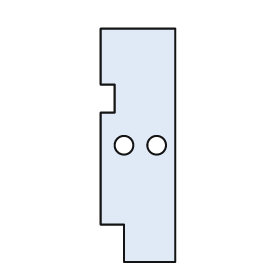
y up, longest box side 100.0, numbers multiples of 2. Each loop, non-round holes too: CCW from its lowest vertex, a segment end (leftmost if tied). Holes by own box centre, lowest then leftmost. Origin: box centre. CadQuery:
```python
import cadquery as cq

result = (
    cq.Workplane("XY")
    .moveTo(-6.0, -50.0)
    .lineTo(16.0, -50.0)
    .lineTo(16.0, 50.0)
    .lineTo(-16.0, 50.0)
    .lineTo(-16.0, 26.0)
    .lineTo(-10.0, 26.0)
    .lineTo(-10.0, 14.0)
    .lineTo(-16.0, 14.0)
    .lineTo(-16.0, -34.0)
    .lineTo(-6.0, -34.0)
    .close()
    .moveTo(-6.0, 0.0)
    .circle(4.0)
    .moveTo(8.0, 0.0)
    .circle(4.0)
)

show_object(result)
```